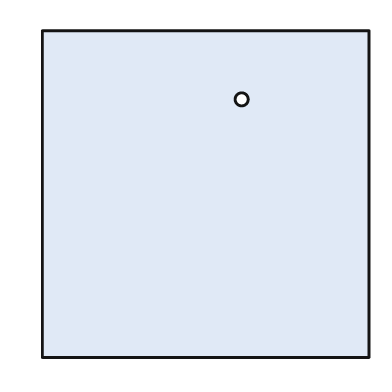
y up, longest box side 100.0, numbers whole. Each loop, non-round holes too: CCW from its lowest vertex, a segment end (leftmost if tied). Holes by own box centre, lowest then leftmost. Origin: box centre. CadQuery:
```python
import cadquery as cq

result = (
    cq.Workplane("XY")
    .moveTo(-50.0, -50.0)
    .lineTo(50.0, -50.0)
    .lineTo(50.0, 50.0)
    .lineTo(-50.0, 50.0)
    .close()
    .moveTo(11.0, 29.0)
    .circle(2.0)
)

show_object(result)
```